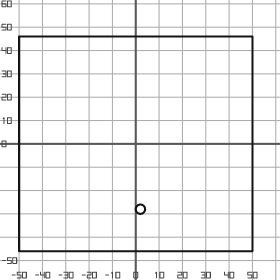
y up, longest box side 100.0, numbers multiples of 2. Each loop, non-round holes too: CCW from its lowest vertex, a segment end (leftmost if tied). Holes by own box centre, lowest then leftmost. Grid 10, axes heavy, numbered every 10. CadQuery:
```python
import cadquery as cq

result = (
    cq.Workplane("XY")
    .moveTo(-50.0, -46.0)
    .lineTo(50.0, -46.0)
    .lineTo(50.0, 46.0)
    .lineTo(-50.0, 46.0)
    .close()
    .moveTo(2.0, -28.0)
    .circle(2.0)
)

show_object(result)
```